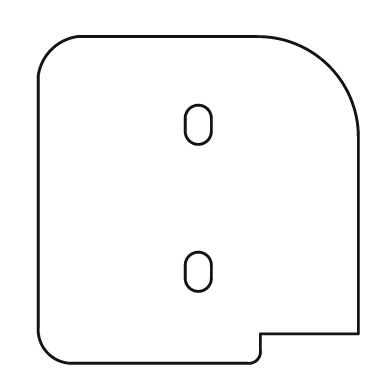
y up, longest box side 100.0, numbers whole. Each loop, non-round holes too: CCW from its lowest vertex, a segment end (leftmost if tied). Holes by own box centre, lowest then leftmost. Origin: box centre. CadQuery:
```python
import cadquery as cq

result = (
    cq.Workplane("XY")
    .moveTo(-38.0, -50.0)
    .lineTo(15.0, -50.0)
    .threePointArc((18.0, -49.0), (19.0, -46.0))
    .lineTo(19.0, -41.0)
    .lineTo(49.0, -41.0)
    .lineTo(49.0, 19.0)
    .threePointArc((40.0, 41.0), (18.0, 50.0))
    .lineTo(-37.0, 50.0)
    .threePointArc((-45.0, 46.0), (-49.0, 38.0))
    .lineTo(-49.0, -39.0)
    .threePointArc((-46.0, -47.0), (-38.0, -50.0))
    .close()
    .moveTo(-4.0, -24.0)
    .threePointArc((0.0, -28.0), (4.0, -24.0))
    .lineTo(4.0, -20.0)
    .threePointArc((0.0, -16.0), (-4.0, -20.0))
    .close()
    .moveTo(-4.0, 21.0)
    .threePointArc((0.0, 17.0), (4.0, 21.0))
    .lineTo(4.0, 25.0)
    .threePointArc((0.0, 29.0), (-4.0, 25.0))
    .close()
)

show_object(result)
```